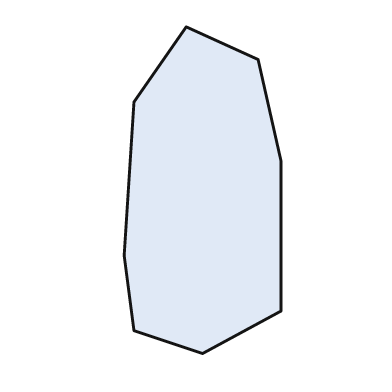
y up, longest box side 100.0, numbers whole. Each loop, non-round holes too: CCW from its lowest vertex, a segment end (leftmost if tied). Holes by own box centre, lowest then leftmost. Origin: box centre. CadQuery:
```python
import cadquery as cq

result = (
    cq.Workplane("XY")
    .moveTo(0.0, -50.0)
    .lineTo(24.0, -37.0)
    .lineTo(24.0, 9.0)
    .lineTo(17.0, 40.0)
    .lineTo(-5.0, 50.0)
    .lineTo(-21.0, 27.0)
    .lineTo(-24.0, -20.0)
    .lineTo(-21.0, -43.0)
    .close()
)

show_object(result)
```